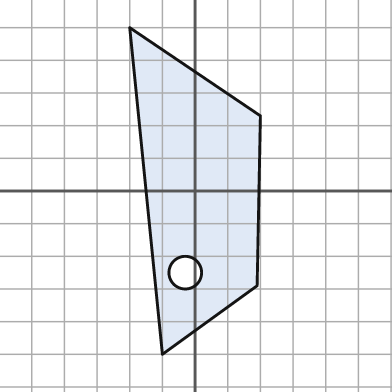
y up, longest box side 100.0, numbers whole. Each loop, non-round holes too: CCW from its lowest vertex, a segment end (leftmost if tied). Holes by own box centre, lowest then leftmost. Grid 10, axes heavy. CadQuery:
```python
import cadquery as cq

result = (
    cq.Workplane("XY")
    .moveTo(-10.0, -50.0)
    .lineTo(19.0, -29.0)
    .lineTo(20.0, 23.0)
    .lineTo(-20.0, 50.0)
    .close()
    .moveTo(-3.0, -25.0)
    .circle(5.0)
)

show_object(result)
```